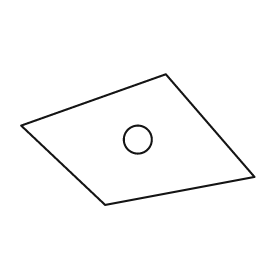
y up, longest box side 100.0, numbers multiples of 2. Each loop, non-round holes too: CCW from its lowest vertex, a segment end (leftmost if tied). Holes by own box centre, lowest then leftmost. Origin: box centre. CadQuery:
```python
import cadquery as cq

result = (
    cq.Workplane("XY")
    .moveTo(-14.0, -28.0)
    .lineTo(50.0, -16.0)
    .lineTo(12.0, 28.0)
    .lineTo(-50.0, 6.0)
    .close()
    .moveTo(0.0, 0.0)
    .circle(6.0)
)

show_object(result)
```